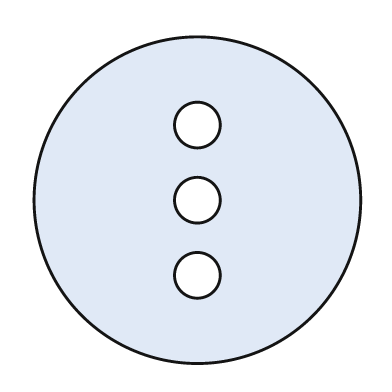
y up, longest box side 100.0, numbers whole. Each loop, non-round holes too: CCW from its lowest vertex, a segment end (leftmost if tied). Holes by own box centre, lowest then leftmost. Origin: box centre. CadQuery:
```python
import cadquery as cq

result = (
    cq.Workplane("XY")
    .moveTo(0.0, 0.0)
    .circle(50.0)
    .moveTo(0.0, -23.0)
    .circle(7.0)
    .moveTo(0.0, 0.0)
    .circle(7.0)
    .moveTo(0.0, 23.0)
    .circle(7.0)
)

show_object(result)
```